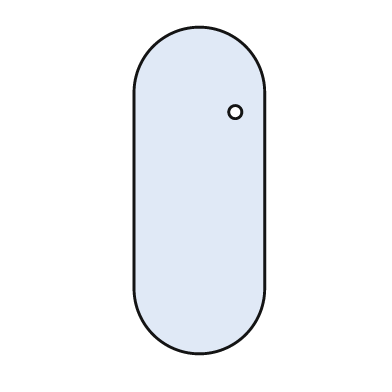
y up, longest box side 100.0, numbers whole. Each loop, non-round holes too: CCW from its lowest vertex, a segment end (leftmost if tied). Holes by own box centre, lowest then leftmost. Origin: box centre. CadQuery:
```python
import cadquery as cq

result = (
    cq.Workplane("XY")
    .moveTo(-20.0, -30.0)
    .threePointArc((0.0, -50.0), (20.0, -30.0))
    .lineTo(20.0, 30.0)
    .threePointArc((0.0, 50.0), (-20.0, 30.0))
    .close()
    .moveTo(11.0, 24.0)
    .circle(2.0)
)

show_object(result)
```